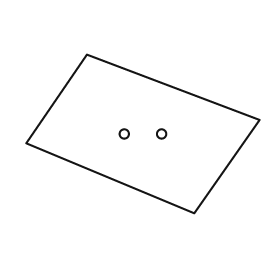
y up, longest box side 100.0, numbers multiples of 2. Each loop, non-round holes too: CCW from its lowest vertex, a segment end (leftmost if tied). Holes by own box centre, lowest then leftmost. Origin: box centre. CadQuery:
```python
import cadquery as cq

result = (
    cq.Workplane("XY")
    .moveTo(22.0, -34.0)
    .lineTo(50.0, 6.0)
    .lineTo(-24.0, 34.0)
    .lineTo(-50.0, -4.0)
    .close()
    .moveTo(-8.0, 0.0)
    .circle(2.0)
    .moveTo(8.0, 0.0)
    .circle(2.0)
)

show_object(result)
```